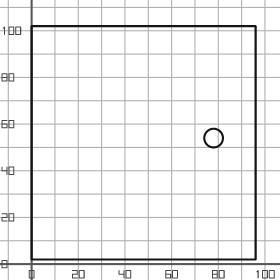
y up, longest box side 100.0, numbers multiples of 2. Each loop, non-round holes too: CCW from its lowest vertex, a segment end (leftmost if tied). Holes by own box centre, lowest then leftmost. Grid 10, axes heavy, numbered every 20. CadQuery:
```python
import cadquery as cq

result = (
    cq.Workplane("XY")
    .moveTo(0.0, 2.0)
    .lineTo(96.0, 2.0)
    .lineTo(96.0, 102.0)
    .lineTo(0.0, 102.0)
    .close()
    .moveTo(78.0, 54.0)
    .circle(4.0)
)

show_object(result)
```